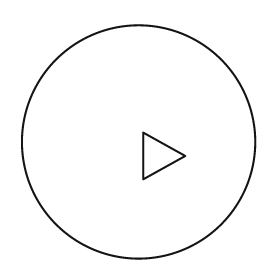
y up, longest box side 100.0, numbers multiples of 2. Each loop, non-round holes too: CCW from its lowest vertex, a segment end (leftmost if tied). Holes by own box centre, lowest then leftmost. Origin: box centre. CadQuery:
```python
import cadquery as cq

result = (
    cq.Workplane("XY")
    .moveTo(0.0, 0.0)
    .circle(50.0)
    .moveTo(2.0, -16.0)
    .lineTo(20.0, -6.0)
    .lineTo(2.0, 4.0)
    .close()
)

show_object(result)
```